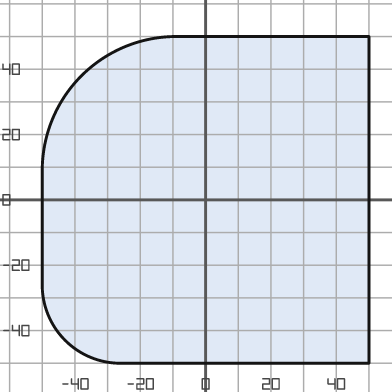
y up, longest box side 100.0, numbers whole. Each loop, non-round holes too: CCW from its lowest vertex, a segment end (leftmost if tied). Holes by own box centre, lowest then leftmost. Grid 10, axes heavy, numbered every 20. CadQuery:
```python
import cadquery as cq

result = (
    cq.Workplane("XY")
    .moveTo(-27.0, -50.0)
    .lineTo(50.0, -50.0)
    .lineTo(50.0, 50.0)
    .lineTo(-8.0, 50.0)
    .threePointArc((-38.0, 38.0), (-50.0, 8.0))
    .lineTo(-50.0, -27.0)
    .threePointArc((-43.0, -43.0), (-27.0, -50.0))
    .close()
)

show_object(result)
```